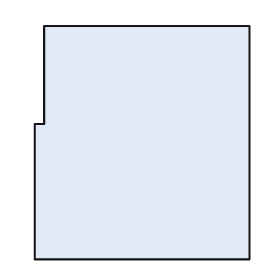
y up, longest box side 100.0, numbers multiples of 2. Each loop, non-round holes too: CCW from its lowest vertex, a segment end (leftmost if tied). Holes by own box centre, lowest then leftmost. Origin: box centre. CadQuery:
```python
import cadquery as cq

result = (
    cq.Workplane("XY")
    .moveTo(-46.0, -50.0)
    .lineTo(46.0, -50.0)
    .lineTo(46.0, 50.0)
    .lineTo(-42.0, 50.0)
    .lineTo(-42.0, 8.0)
    .lineTo(-46.0, 8.0)
    .close()
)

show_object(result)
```